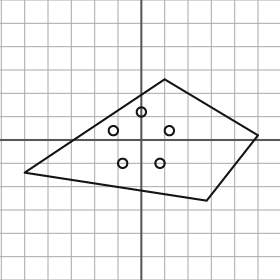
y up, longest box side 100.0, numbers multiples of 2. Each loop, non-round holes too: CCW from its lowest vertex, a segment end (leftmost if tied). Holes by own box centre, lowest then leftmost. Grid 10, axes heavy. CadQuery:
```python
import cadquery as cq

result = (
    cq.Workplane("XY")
    .moveTo(28.0, -26.0)
    .lineTo(50.0, 2.0)
    .lineTo(10.0, 26.0)
    .lineTo(-50.0, -14.0)
    .close()
    .moveTo(-8.0, -10.0)
    .circle(2.0)
    .moveTo(8.0, -10.0)
    .circle(2.0)
    .moveTo(-12.0, 4.0)
    .circle(2.0)
    .moveTo(12.0, 4.0)
    .circle(2.0)
    .moveTo(0.0, 12.0)
    .circle(2.0)
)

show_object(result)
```